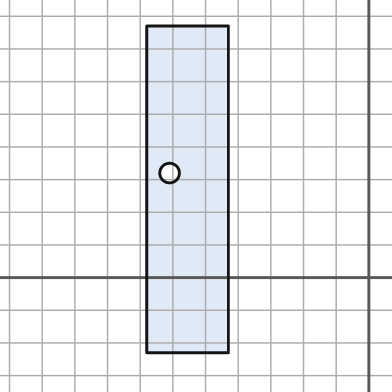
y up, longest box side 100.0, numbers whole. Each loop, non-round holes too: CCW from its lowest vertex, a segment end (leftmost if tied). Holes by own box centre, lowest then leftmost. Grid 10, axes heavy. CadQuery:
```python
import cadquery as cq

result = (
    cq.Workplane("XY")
    .moveTo(-68.0, -23.0)
    .lineTo(-43.0, -23.0)
    .lineTo(-43.0, 77.0)
    .lineTo(-68.0, 77.0)
    .close()
    .moveTo(-61.0, 32.0)
    .circle(3.0)
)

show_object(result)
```